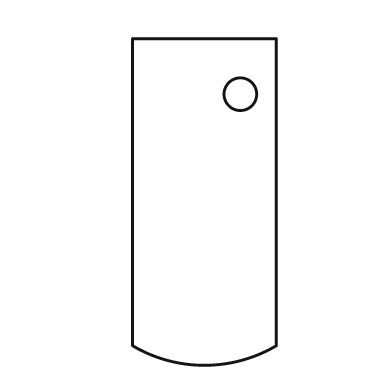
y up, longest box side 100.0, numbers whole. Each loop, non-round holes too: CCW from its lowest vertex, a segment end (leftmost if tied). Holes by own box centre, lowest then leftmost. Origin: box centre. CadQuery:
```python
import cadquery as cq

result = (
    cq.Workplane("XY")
    .moveTo(-22.0, -44.0)
    .threePointArc((0.0, -50.0), (22.0, -44.0))
    .lineTo(22.0, 50.0)
    .lineTo(-22.0, 50.0)
    .close()
    .moveTo(11.0, 33.0)
    .circle(5.0)
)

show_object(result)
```